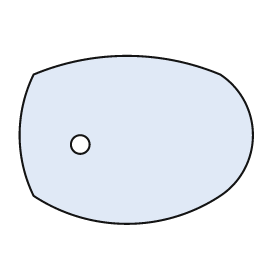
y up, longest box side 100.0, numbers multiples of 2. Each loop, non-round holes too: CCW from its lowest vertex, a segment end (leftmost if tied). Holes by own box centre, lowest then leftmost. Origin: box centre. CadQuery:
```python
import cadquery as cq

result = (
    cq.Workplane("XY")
    .moveTo(-44.0, -24.0)
    .threePointArc((-4.0, -36.0), (36.0, -24.0))
    .threePointArc((50.0, 2.0), (36.0, 28.0))
    .threePointArc((-4.0, 36.0), (-44.0, 28.0))
    .threePointArc((-50.0, 2.0), (-44.0, -24.0))
    .close()
    .moveTo(-24.0, -2.0)
    .circle(4.0)
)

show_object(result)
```